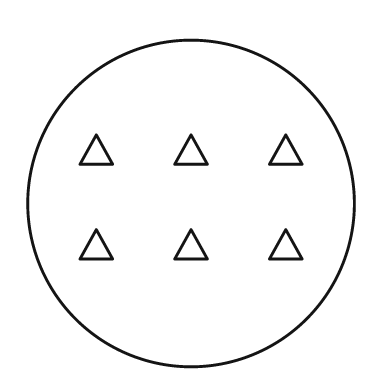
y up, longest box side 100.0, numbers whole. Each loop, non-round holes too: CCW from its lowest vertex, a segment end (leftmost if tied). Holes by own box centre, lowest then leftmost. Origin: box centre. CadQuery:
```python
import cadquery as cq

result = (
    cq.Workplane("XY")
    .moveTo(0.0, 0.0)
    .circle(50.0)
    .moveTo(-34.0, -17.0)
    .lineTo(-24.0, -17.0)
    .lineTo(-29.0, -8.0)
    .close()
    .moveTo(-5.0, -17.0)
    .lineTo(5.0, -17.0)
    .lineTo(0.0, -8.0)
    .close()
    .moveTo(24.0, -17.0)
    .lineTo(34.0, -17.0)
    .lineTo(29.0, -8.0)
    .close()
    .moveTo(-34.0, 12.0)
    .lineTo(-24.0, 12.0)
    .lineTo(-29.0, 21.0)
    .close()
    .moveTo(-5.0, 12.0)
    .lineTo(5.0, 12.0)
    .lineTo(0.0, 21.0)
    .close()
    .moveTo(24.0, 12.0)
    .lineTo(34.0, 12.0)
    .lineTo(29.0, 21.0)
    .close()
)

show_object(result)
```